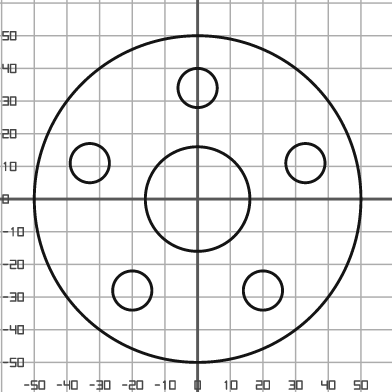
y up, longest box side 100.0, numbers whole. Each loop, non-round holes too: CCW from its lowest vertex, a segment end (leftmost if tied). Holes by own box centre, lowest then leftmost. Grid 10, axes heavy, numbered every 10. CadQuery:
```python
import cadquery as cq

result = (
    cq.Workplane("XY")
    .moveTo(0.0, 0.0)
    .circle(50.0)
    .moveTo(-20.0, -28.0)
    .circle(6.0)
    .moveTo(20.0, -28.0)
    .circle(6.0)
    .moveTo(0.0, 0.0)
    .circle(16.0)
    .moveTo(-33.0, 11.0)
    .circle(6.0)
    .moveTo(33.0, 11.0)
    .circle(6.0)
    .moveTo(0.0, 34.0)
    .circle(6.0)
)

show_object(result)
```